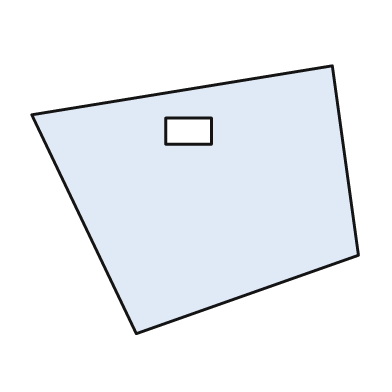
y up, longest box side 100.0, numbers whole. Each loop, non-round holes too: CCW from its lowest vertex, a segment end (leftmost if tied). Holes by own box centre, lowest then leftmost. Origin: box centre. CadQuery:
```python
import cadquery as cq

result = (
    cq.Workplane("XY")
    .moveTo(-18.0, -41.0)
    .lineTo(50.0, -17.0)
    .lineTo(42.0, 41.0)
    .lineTo(-50.0, 26.0)
    .close()
    .moveTo(-9.0, 17.0)
    .lineTo(5.0, 17.0)
    .lineTo(5.0, 25.0)
    .lineTo(-9.0, 25.0)
    .close()
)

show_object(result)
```